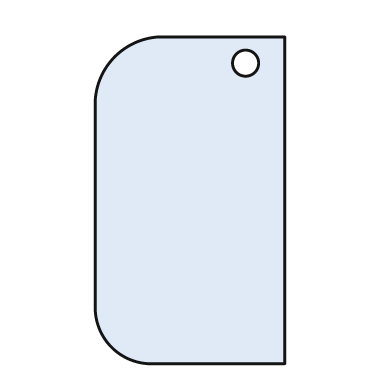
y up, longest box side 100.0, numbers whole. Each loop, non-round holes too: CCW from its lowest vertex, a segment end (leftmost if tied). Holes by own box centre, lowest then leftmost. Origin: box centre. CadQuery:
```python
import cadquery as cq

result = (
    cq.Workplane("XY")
    .moveTo(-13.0, -50.0)
    .lineTo(29.0, -50.0)
    .lineTo(29.0, 50.0)
    .lineTo(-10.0, 50.0)
    .threePointArc((-23.0, 44.0), (-29.0, 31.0))
    .lineTo(-29.0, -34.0)
    .threePointArc((-24.0, -45.0), (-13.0, -50.0))
    .close()
    .moveTo(17.0, 42.0)
    .circle(4.0)
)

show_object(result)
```